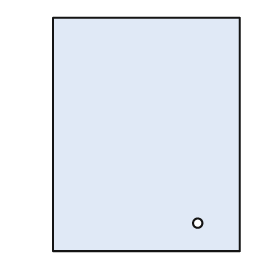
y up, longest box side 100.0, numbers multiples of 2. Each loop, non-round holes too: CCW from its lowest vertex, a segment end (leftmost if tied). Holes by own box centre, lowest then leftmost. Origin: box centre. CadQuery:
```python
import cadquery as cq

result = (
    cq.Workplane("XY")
    .moveTo(-40.0, -50.0)
    .lineTo(40.0, -50.0)
    .lineTo(40.0, 50.0)
    .lineTo(-40.0, 50.0)
    .close()
    .moveTo(22.0, -38.0)
    .circle(2.0)
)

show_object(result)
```